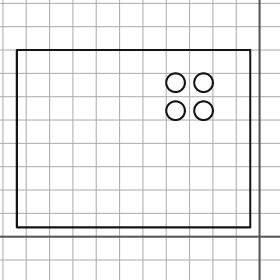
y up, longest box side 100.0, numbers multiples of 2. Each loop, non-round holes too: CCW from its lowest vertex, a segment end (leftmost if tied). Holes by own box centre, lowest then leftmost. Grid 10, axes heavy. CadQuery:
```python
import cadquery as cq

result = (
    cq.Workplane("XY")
    .moveTo(-104.0, 4.0)
    .lineTo(-4.0, 4.0)
    .lineTo(-4.0, 80.0)
    .lineTo(-104.0, 80.0)
    .close()
    .moveTo(-36.0, 54.0)
    .circle(4.0)
    .moveTo(-24.0, 54.0)
    .circle(4.0)
    .moveTo(-36.0, 66.0)
    .circle(4.0)
    .moveTo(-24.0, 66.0)
    .circle(4.0)
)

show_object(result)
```